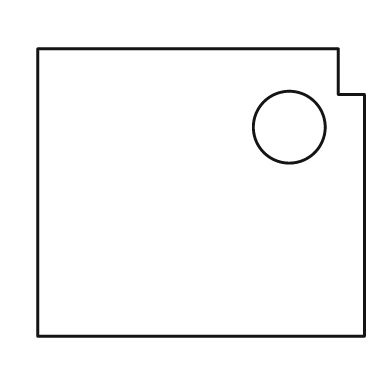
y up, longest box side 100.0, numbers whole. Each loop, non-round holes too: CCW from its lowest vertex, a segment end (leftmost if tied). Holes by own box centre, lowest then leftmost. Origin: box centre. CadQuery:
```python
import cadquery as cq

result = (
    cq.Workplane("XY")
    .moveTo(-50.0, -44.0)
    .lineTo(50.0, -44.0)
    .lineTo(50.0, 30.0)
    .lineTo(42.0, 30.0)
    .lineTo(42.0, 44.0)
    .lineTo(-50.0, 44.0)
    .close()
    .moveTo(27.0, 20.0)
    .circle(11.0)
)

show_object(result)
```